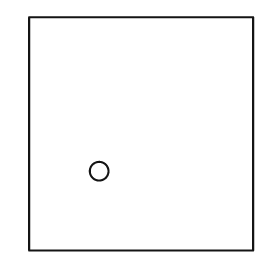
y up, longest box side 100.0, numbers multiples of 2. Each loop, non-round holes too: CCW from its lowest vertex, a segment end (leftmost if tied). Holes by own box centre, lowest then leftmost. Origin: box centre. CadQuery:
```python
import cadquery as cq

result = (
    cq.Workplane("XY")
    .moveTo(-48.0, -50.0)
    .lineTo(48.0, -50.0)
    .lineTo(48.0, 50.0)
    .lineTo(-48.0, 50.0)
    .close()
    .moveTo(-18.0, -16.0)
    .circle(4.0)
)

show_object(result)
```